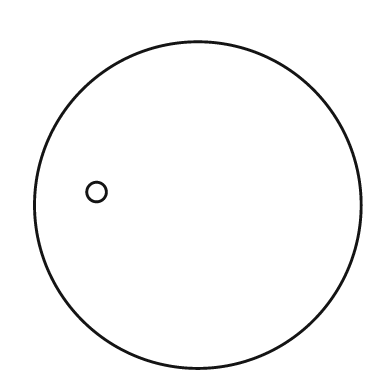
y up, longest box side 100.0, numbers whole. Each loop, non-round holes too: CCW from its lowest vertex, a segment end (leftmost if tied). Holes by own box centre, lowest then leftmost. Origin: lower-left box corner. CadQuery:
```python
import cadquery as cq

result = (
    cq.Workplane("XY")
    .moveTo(50.0, 50.0)
    .circle(50.0)
    .moveTo(19.0, 54.0)
    .circle(3.0)
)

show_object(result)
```